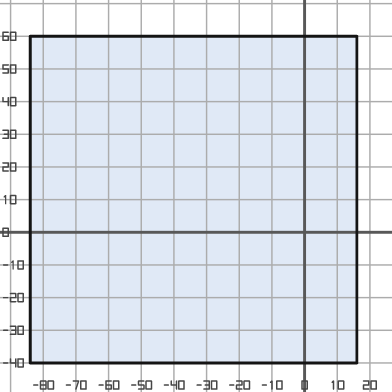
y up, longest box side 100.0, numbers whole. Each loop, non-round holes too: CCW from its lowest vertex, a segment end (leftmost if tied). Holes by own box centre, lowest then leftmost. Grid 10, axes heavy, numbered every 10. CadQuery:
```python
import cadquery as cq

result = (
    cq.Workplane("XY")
    .moveTo(-84.0, -40.0)
    .lineTo(16.0, -40.0)
    .lineTo(16.0, 60.0)
    .lineTo(-84.0, 60.0)
    .close()
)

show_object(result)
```